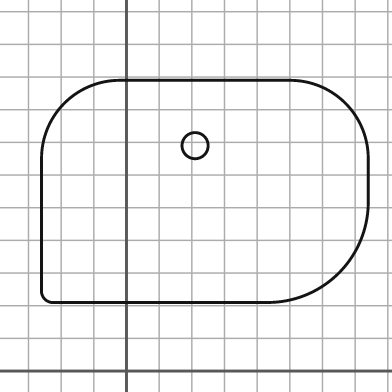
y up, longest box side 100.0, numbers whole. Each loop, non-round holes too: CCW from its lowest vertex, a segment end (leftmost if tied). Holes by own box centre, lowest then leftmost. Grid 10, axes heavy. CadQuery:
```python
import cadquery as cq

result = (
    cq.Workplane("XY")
    .moveTo(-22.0, 21.0)
    .lineTo(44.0, 21.0)
    .threePointArc((65.0, 30.0), (74.0, 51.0))
    .lineTo(74.0, 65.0)
    .threePointArc((67.0, 82.0), (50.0, 89.0))
    .lineTo(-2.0, 89.0)
    .threePointArc((-19.0, 82.0), (-26.0, 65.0))
    .lineTo(-26.0, 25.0)
    .threePointArc((-25.0, 22.0), (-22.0, 21.0))
    .close()
    .moveTo(21.0, 69.0)
    .circle(4.0)
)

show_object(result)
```